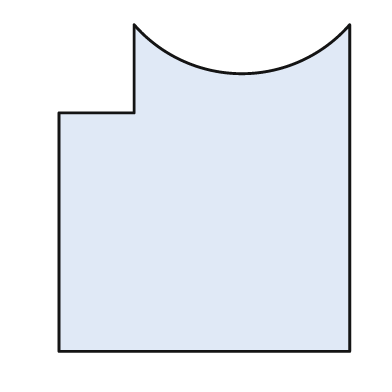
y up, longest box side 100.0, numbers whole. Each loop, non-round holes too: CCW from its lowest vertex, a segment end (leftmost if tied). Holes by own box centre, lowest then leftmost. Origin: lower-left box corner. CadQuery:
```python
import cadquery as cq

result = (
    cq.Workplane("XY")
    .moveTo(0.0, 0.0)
    .lineTo(89.0, 0.0)
    .lineTo(89.0, 100.0)
    .threePointArc((56.0, 85.0), (23.0, 100.0))
    .lineTo(23.0, 73.0)
    .lineTo(0.0, 73.0)
    .close()
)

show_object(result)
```